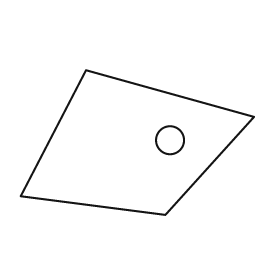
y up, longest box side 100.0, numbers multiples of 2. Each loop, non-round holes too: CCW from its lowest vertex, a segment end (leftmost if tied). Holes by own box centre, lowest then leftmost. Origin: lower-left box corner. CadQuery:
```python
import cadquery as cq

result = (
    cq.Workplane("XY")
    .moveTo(62.0, 0.0)
    .lineTo(100.0, 42.0)
    .lineTo(28.0, 62.0)
    .lineTo(0.0, 8.0)
    .close()
    .moveTo(64.0, 32.0)
    .circle(6.0)
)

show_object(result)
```